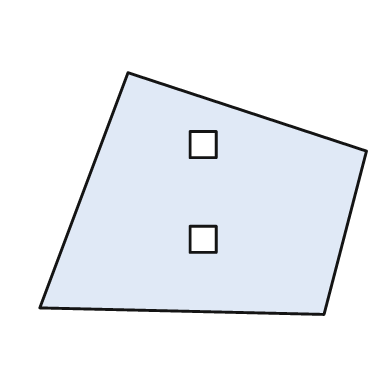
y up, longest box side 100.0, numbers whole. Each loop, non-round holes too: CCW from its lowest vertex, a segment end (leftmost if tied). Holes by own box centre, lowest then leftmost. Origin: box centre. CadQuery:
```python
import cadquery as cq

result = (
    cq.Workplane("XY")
    .moveTo(37.0, -37.0)
    .lineTo(50.0, 13.0)
    .lineTo(-23.0, 37.0)
    .lineTo(-50.0, -35.0)
    .close()
    .moveTo(-4.0, -18.0)
    .lineTo(4.0, -18.0)
    .lineTo(4.0, -10.0)
    .lineTo(-4.0, -10.0)
    .close()
    .moveTo(-4.0, 11.0)
    .lineTo(4.0, 11.0)
    .lineTo(4.0, 19.0)
    .lineTo(-4.0, 19.0)
    .close()
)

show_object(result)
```